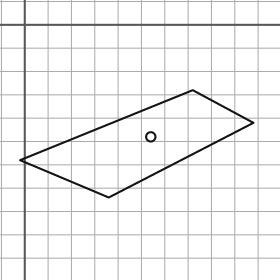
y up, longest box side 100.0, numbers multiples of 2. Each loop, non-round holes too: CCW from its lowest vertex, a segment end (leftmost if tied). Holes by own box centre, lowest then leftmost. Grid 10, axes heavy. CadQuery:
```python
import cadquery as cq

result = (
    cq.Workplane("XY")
    .moveTo(36.0, -74.0)
    .lineTo(98.0, -42.0)
    .lineTo(72.0, -28.0)
    .lineTo(-2.0, -58.0)
    .close()
    .moveTo(54.0, -48.0)
    .circle(2.0)
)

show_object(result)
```